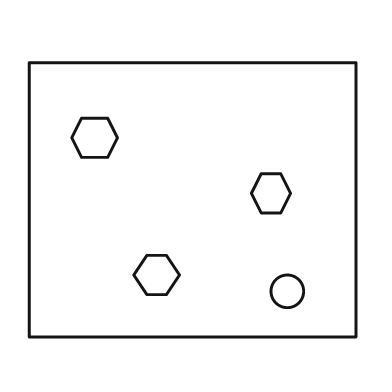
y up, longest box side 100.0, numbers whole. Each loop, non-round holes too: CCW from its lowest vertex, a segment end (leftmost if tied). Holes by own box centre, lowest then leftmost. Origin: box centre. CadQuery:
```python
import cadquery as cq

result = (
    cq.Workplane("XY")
    .moveTo(-50.0, -42.0)
    .lineTo(50.0, -42.0)
    .lineTo(50.0, 42.0)
    .lineTo(-50.0, 42.0)
    .close()
    .moveTo(29.0, -28.0)
    .circle(5.0)
    .moveTo(-14.0, -29.0)
    .lineTo(-8.0, -29.0)
    .lineTo(-4.0, -23.0)
    .lineTo(-8.0, -17.0)
    .lineTo(-14.0, -17.0)
    .lineTo(-18.0, -23.0)
    .close()
    .moveTo(21.0, -4.0)
    .lineTo(27.0, -4.0)
    .lineTo(30.0, 2.0)
    .lineTo(27.0, 8.0)
    .lineTo(21.0, 8.0)
    .lineTo(18.0, 2.0)
    .close()
    .moveTo(-34.0, 13.0)
    .lineTo(-26.0, 13.0)
    .lineTo(-23.0, 19.0)
    .lineTo(-26.0, 25.0)
    .lineTo(-34.0, 25.0)
    .lineTo(-37.0, 19.0)
    .close()
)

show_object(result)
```